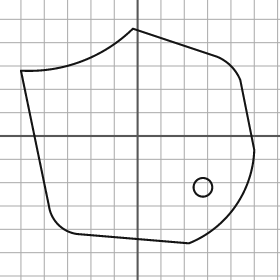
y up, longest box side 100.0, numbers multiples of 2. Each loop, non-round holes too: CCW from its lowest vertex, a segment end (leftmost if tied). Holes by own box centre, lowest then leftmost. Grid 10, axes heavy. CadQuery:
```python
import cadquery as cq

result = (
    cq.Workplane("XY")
    .moveTo(22.0, -46.0)
    .threePointArc((42.0, -30.0), (50.0, -6.0))
    .lineTo(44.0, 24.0)
    .threePointArc((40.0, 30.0), (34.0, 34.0))
    .lineTo(-2.0, 46.0)
    .threePointArc((-24.0, 32.0), (-50.0, 28.0))
    .lineTo(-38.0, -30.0)
    .threePointArc((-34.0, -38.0), (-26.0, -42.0))
    .close()
    .moveTo(28.0, -22.0)
    .circle(4.0)
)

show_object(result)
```